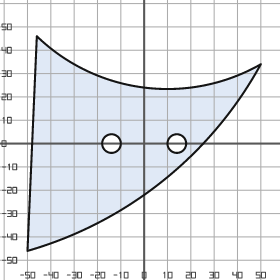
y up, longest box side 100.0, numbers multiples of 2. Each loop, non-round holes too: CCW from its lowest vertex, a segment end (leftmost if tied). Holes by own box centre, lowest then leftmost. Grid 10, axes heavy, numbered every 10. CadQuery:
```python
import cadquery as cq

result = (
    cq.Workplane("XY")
    .moveTo(-50.0, -46.0)
    .threePointArc((8.0, -16.0), (50.0, 34.0))
    .threePointArc((0.0, 24.0), (-46.0, 46.0))
    .close()
    .moveTo(-14.0, 0.0)
    .circle(4.0)
    .moveTo(14.0, 0.0)
    .circle(4.0)
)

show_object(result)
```